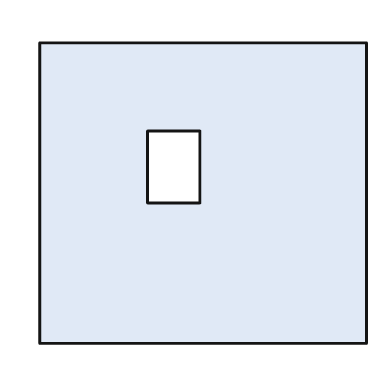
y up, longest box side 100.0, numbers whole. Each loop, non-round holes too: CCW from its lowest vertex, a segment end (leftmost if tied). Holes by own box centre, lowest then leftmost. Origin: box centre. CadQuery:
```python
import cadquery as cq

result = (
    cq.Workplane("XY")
    .moveTo(-50.0, -46.0)
    .lineTo(50.0, -46.0)
    .lineTo(50.0, 46.0)
    .lineTo(-50.0, 46.0)
    .close()
    .moveTo(-17.0, -3.0)
    .lineTo(-1.0, -3.0)
    .lineTo(-1.0, 19.0)
    .lineTo(-17.0, 19.0)
    .close()
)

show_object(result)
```